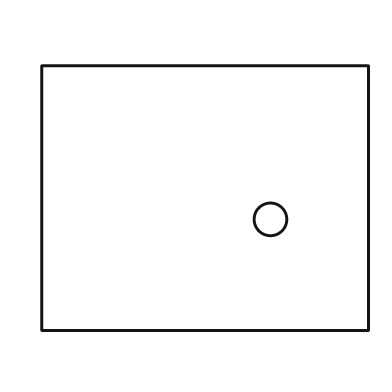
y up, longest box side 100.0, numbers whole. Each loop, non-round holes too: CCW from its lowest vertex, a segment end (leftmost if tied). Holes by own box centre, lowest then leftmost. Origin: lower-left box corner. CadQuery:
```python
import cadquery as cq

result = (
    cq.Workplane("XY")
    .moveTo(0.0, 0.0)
    .lineTo(100.0, 0.0)
    .lineTo(100.0, 81.0)
    .lineTo(0.0, 81.0)
    .close()
    .moveTo(70.0, 34.0)
    .circle(5.0)
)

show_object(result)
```